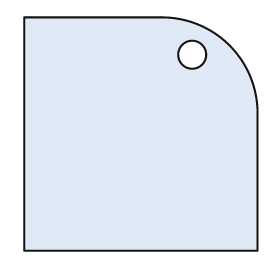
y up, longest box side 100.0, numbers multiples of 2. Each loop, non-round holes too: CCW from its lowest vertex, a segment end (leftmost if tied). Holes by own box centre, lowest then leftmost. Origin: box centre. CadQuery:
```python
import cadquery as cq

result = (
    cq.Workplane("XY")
    .moveTo(-50.0, -50.0)
    .lineTo(50.0, -50.0)
    .lineTo(50.0, 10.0)
    .threePointArc((38.0, 38.0), (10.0, 50.0))
    .lineTo(-50.0, 50.0)
    .close()
    .moveTo(22.0, 34.0)
    .circle(6.0)
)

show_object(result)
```